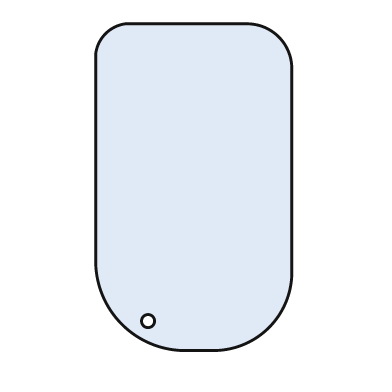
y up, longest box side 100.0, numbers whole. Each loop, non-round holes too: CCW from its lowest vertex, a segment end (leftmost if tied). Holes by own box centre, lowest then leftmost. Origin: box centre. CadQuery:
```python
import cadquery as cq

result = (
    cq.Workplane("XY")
    .moveTo(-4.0, -50.0)
    .lineTo(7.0, -50.0)
    .threePointArc((23.0, -43.0), (30.0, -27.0))
    .lineTo(30.0, 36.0)
    .threePointArc((26.0, 46.0), (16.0, 50.0))
    .lineTo(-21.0, 50.0)
    .threePointArc((-27.0, 47.0), (-30.0, 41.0))
    .lineTo(-30.0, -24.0)
    .threePointArc((-22.0, -42.0), (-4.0, -50.0))
    .close()
    .moveTo(-14.0, -41.0)
    .circle(2.0)
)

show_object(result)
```